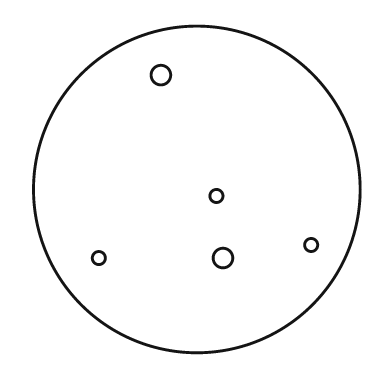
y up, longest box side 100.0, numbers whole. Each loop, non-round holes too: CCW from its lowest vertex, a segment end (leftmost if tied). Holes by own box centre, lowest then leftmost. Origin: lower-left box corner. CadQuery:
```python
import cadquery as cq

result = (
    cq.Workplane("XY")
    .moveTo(50.0, 50.0)
    .circle(50.0)
    .moveTo(20.0, 29.0)
    .circle(2.0)
    .moveTo(58.0, 29.0)
    .circle(3.0)
    .moveTo(85.0, 33.0)
    .circle(2.0)
    .moveTo(56.0, 48.0)
    .circle(2.0)
    .moveTo(39.0, 85.0)
    .circle(3.0)
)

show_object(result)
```